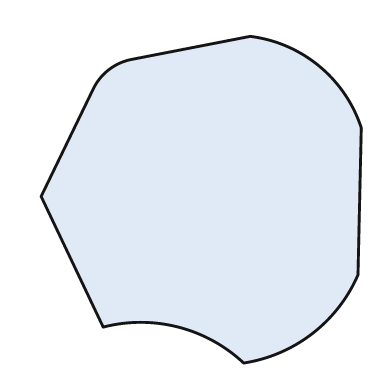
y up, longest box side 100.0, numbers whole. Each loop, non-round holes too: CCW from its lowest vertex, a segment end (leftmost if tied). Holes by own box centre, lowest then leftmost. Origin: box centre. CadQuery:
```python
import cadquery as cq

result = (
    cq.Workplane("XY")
    .moveTo(13.0, -50.0)
    .threePointArc((34.0, -41.0), (48.0, -23.0))
    .lineTo(49.0, 22.0)
    .threePointArc((36.0, 41.0), (15.0, 50.0))
    .lineTo(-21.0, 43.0)
    .threePointArc((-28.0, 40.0), (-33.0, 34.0))
    .lineTo(-49.0, 1.0)
    .lineTo(-30.0, -39.0)
    .threePointArc((-7.0, -39.0), (13.0, -50.0))
    .close()
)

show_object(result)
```